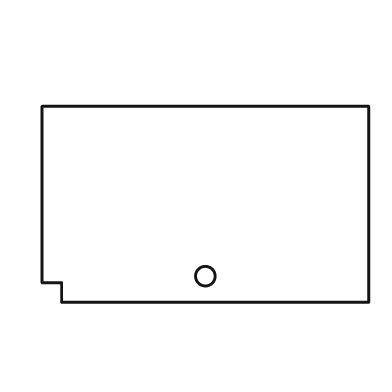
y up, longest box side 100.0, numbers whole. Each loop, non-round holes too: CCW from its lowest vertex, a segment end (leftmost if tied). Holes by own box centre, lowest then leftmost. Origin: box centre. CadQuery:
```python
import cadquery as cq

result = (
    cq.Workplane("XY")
    .moveTo(-44.0, -30.0)
    .lineTo(50.0, -30.0)
    .lineTo(50.0, 30.0)
    .lineTo(-50.0, 30.0)
    .lineTo(-50.0, -24.0)
    .lineTo(-44.0, -24.0)
    .close()
    .moveTo(0.0, -22.0)
    .circle(3.0)
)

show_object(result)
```